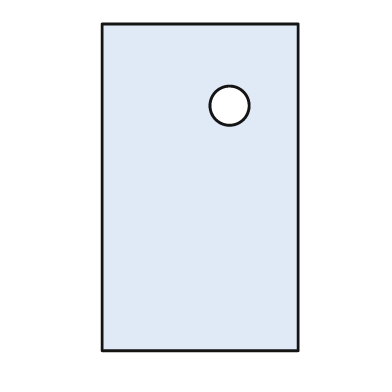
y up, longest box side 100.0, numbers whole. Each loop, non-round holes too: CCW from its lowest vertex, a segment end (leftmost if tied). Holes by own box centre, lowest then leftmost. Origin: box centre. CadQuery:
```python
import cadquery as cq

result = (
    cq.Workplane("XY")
    .moveTo(-30.0, -50.0)
    .lineTo(30.0, -50.0)
    .lineTo(30.0, 50.0)
    .lineTo(-30.0, 50.0)
    .close()
    .moveTo(9.0, 25.0)
    .circle(6.0)
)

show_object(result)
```